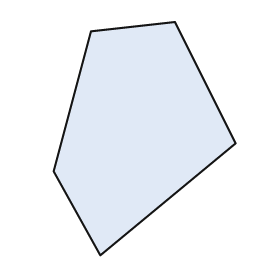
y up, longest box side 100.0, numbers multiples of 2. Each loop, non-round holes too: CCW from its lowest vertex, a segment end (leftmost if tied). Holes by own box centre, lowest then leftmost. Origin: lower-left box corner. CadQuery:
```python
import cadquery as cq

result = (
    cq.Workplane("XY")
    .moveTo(20.0, 0.0)
    .lineTo(78.0, 48.0)
    .lineTo(52.0, 100.0)
    .lineTo(16.0, 96.0)
    .lineTo(0.0, 36.0)
    .close()
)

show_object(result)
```